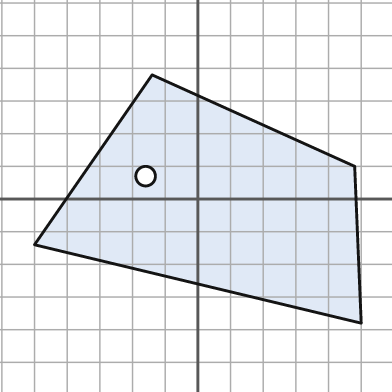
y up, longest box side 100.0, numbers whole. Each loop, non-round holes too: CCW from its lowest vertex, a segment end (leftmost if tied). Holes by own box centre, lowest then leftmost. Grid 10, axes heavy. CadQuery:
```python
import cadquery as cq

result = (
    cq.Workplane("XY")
    .moveTo(50.0, -38.0)
    .lineTo(48.0, 10.0)
    .lineTo(-14.0, 38.0)
    .lineTo(-50.0, -14.0)
    .close()
    .moveTo(-16.0, 7.0)
    .circle(3.0)
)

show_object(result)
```